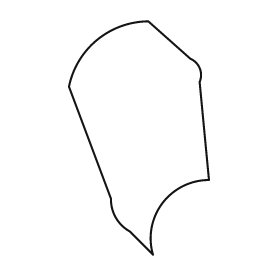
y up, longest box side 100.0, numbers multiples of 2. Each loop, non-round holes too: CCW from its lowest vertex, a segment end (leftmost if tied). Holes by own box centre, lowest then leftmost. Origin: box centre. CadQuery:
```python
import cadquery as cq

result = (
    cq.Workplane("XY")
    .moveTo(6.0, -50.0)
    .threePointArc((10.0, -28.0), (30.0, -18.0))
    .lineTo(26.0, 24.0)
    .threePointArc((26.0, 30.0), (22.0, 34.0))
    .lineTo(4.0, 50.0)
    .threePointArc((-18.0, 42.0), (-30.0, 22.0))
    .lineTo(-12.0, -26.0)
    .threePointArc((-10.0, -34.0), (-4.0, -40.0))
    .close()
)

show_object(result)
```